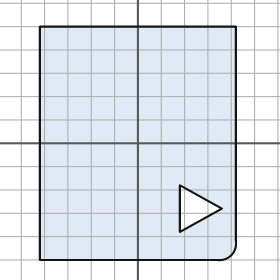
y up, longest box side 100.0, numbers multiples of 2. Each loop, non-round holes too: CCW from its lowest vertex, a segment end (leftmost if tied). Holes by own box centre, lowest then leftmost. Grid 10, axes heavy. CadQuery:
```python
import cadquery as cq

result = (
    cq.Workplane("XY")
    .moveTo(-42.0, -50.0)
    .lineTo(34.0, -50.0)
    .threePointArc((40.0, -48.0), (42.0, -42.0))
    .lineTo(42.0, 50.0)
    .lineTo(-42.0, 50.0)
    .close()
    .moveTo(18.0, -38.0)
    .lineTo(36.0, -28.0)
    .lineTo(18.0, -18.0)
    .close()
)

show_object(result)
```